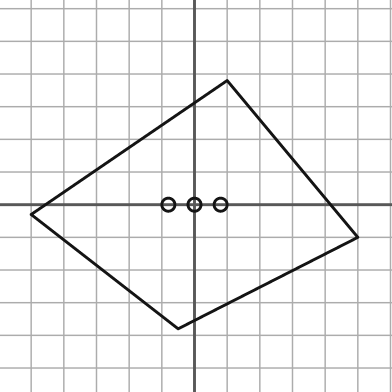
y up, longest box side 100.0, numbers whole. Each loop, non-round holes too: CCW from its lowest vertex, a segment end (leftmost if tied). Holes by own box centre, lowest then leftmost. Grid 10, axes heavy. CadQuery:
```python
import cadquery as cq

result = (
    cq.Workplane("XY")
    .moveTo(-5.0, -38.0)
    .lineTo(50.0, -10.0)
    .lineTo(10.0, 38.0)
    .lineTo(-50.0, -3.0)
    .close()
    .moveTo(-8.0, 0.0)
    .circle(2.0)
    .moveTo(0.0, 0.0)
    .circle(2.0)
    .moveTo(8.0, 0.0)
    .circle(2.0)
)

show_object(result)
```